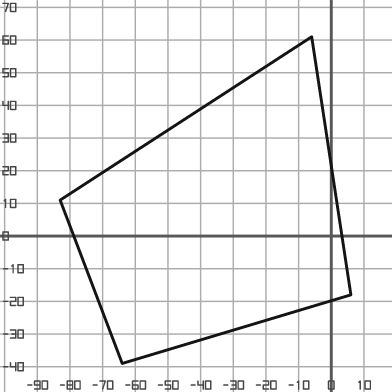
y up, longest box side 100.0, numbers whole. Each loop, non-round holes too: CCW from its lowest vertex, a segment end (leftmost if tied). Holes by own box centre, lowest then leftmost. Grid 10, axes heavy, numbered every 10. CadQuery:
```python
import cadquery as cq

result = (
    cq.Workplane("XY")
    .moveTo(-64.0, -39.0)
    .lineTo(6.0, -18.0)
    .lineTo(-6.0, 61.0)
    .lineTo(-83.0, 11.0)
    .close()
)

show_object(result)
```